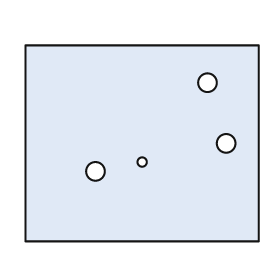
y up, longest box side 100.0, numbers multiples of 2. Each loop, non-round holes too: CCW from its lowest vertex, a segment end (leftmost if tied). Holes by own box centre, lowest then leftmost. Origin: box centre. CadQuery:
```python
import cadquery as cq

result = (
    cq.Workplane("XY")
    .moveTo(-50.0, -42.0)
    .lineTo(50.0, -42.0)
    .lineTo(50.0, 42.0)
    .lineTo(-50.0, 42.0)
    .close()
    .moveTo(-20.0, -12.0)
    .circle(4.0)
    .moveTo(0.0, -8.0)
    .circle(2.0)
    .moveTo(36.0, 0.0)
    .circle(4.0)
    .moveTo(28.0, 26.0)
    .circle(4.0)
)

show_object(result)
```